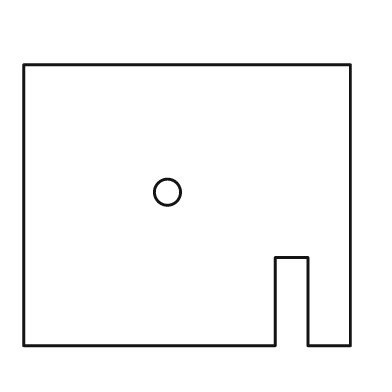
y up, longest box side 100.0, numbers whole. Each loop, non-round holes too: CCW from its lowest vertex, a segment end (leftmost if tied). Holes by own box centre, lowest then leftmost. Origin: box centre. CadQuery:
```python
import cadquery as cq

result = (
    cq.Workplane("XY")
    .moveTo(-50.0, -43.0)
    .lineTo(27.0, -43.0)
    .lineTo(27.0, -16.0)
    .lineTo(37.0, -16.0)
    .lineTo(37.0, -43.0)
    .lineTo(50.0, -43.0)
    .lineTo(50.0, 43.0)
    .lineTo(-50.0, 43.0)
    .close()
    .moveTo(-6.0, 4.0)
    .circle(4.0)
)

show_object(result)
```